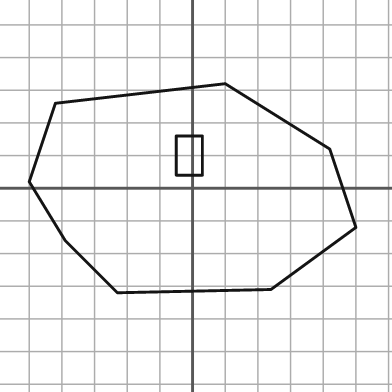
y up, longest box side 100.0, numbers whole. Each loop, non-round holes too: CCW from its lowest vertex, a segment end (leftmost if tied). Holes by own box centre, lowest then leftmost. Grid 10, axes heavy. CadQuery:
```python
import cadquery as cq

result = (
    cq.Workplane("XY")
    .moveTo(-23.0, -32.0)
    .lineTo(24.0, -31.0)
    .lineTo(50.0, -12.0)
    .lineTo(42.0, 12.0)
    .lineTo(10.0, 32.0)
    .lineTo(-42.0, 26.0)
    .lineTo(-50.0, 2.0)
    .lineTo(-39.0, -16.0)
    .close()
    .moveTo(-5.0, 4.0)
    .lineTo(3.0, 4.0)
    .lineTo(3.0, 16.0)
    .lineTo(-5.0, 16.0)
    .close()
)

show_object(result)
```